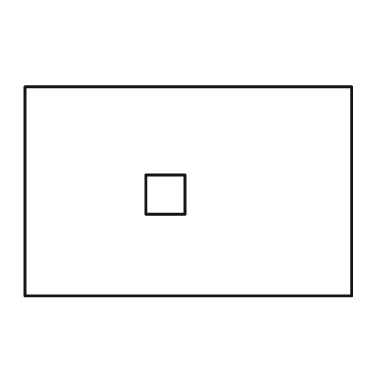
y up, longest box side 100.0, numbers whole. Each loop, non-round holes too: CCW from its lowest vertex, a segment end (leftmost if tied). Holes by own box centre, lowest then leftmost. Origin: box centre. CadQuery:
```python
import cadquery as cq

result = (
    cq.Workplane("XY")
    .moveTo(-50.0, -32.0)
    .lineTo(50.0, -32.0)
    .lineTo(50.0, 32.0)
    .lineTo(-50.0, 32.0)
    .close()
    .moveTo(-13.0, -7.0)
    .lineTo(-1.0, -7.0)
    .lineTo(-1.0, 5.0)
    .lineTo(-13.0, 5.0)
    .close()
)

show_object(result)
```